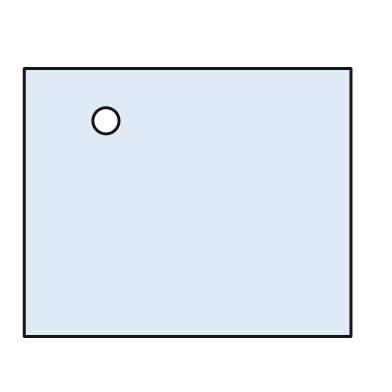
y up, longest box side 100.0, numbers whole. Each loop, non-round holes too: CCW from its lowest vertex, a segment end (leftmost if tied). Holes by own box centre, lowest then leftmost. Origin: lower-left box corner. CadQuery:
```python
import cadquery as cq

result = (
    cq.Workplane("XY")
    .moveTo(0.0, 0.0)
    .lineTo(100.0, 0.0)
    .lineTo(100.0, 82.0)
    .lineTo(0.0, 82.0)
    .close()
    .moveTo(25.0, 66.0)
    .circle(4.0)
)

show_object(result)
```